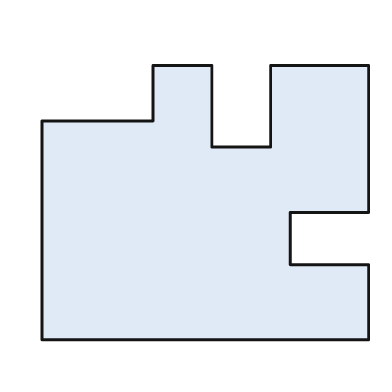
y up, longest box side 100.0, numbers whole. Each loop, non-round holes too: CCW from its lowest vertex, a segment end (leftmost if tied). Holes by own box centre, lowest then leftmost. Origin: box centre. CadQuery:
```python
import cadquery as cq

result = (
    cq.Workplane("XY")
    .moveTo(-50.0, -42.0)
    .lineTo(50.0, -42.0)
    .lineTo(50.0, -19.0)
    .lineTo(26.0, -19.0)
    .lineTo(26.0, -3.0)
    .lineTo(50.0, -3.0)
    .lineTo(50.0, 42.0)
    .lineTo(20.0, 42.0)
    .lineTo(20.0, 17.0)
    .lineTo(2.0, 17.0)
    .lineTo(2.0, 42.0)
    .lineTo(-16.0, 42.0)
    .lineTo(-16.0, 25.0)
    .lineTo(-50.0, 25.0)
    .close()
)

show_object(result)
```